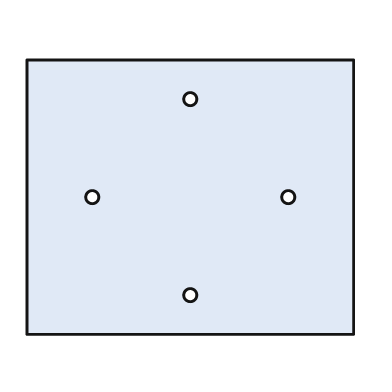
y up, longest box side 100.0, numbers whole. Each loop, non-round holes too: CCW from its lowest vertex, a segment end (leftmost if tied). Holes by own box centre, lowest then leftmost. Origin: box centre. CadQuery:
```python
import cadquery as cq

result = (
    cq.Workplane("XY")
    .moveTo(-50.0, -42.0)
    .lineTo(50.0, -42.0)
    .lineTo(50.0, 42.0)
    .lineTo(-50.0, 42.0)
    .close()
    .moveTo(0.0, -30.0)
    .circle(2.0)
    .moveTo(-30.0, 0.0)
    .circle(2.0)
    .moveTo(30.0, 0.0)
    .circle(2.0)
    .moveTo(0.0, 30.0)
    .circle(2.0)
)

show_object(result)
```